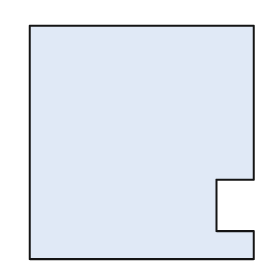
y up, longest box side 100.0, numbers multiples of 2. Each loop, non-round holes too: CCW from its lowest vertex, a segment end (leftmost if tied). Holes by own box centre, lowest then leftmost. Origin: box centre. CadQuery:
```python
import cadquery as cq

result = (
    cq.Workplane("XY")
    .moveTo(-48.0, -50.0)
    .lineTo(48.0, -50.0)
    .lineTo(48.0, -38.0)
    .lineTo(32.0, -38.0)
    .lineTo(32.0, -16.0)
    .lineTo(48.0, -16.0)
    .lineTo(48.0, 50.0)
    .lineTo(-48.0, 50.0)
    .close()
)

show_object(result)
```